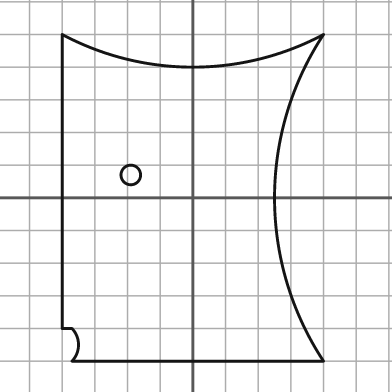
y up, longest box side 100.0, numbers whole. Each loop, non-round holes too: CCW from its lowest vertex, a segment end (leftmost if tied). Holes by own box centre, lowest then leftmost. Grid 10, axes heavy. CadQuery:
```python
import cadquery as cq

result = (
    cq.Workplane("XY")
    .moveTo(-37.0, -50.0)
    .lineTo(40.0, -50.0)
    .threePointArc((25.0, 0.0), (40.0, 50.0))
    .threePointArc((0.0, 40.0), (-40.0, 50.0))
    .lineTo(-40.0, -40.0)
    .lineTo(-37.0, -40.0)
    .threePointArc((-35.0, -45.0), (-37.0, -50.0))
    .close()
    .moveTo(-19.0, 7.0)
    .circle(3.0)
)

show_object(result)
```